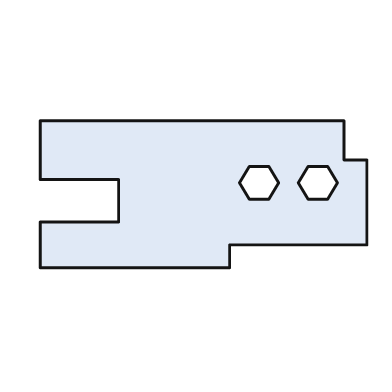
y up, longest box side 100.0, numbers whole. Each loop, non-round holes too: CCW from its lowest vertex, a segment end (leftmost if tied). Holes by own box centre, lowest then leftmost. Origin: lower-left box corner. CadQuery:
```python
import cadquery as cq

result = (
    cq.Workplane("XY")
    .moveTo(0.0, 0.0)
    .lineTo(58.0, 0.0)
    .lineTo(58.0, 7.0)
    .lineTo(100.0, 7.0)
    .lineTo(100.0, 33.0)
    .lineTo(93.0, 33.0)
    .lineTo(93.0, 45.0)
    .lineTo(0.0, 45.0)
    .lineTo(0.0, 27.0)
    .lineTo(24.0, 27.0)
    .lineTo(24.0, 14.0)
    .lineTo(0.0, 14.0)
    .close()
    .moveTo(64.0, 21.0)
    .lineTo(70.0, 21.0)
    .lineTo(73.0, 26.0)
    .lineTo(70.0, 31.0)
    .lineTo(64.0, 31.0)
    .lineTo(61.0, 26.0)
    .close()
    .moveTo(82.0, 21.0)
    .lineTo(88.0, 21.0)
    .lineTo(91.0, 26.0)
    .lineTo(88.0, 31.0)
    .lineTo(82.0, 31.0)
    .lineTo(79.0, 26.0)
    .close()
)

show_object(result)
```